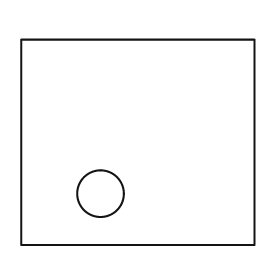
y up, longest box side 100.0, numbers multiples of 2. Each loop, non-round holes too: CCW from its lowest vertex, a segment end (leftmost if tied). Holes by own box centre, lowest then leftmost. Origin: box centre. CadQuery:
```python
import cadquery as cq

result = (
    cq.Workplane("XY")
    .moveTo(-50.0, -44.0)
    .lineTo(50.0, -44.0)
    .lineTo(50.0, 44.0)
    .lineTo(-50.0, 44.0)
    .close()
    .moveTo(-16.0, -22.0)
    .circle(10.0)
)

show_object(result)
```